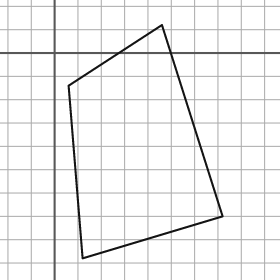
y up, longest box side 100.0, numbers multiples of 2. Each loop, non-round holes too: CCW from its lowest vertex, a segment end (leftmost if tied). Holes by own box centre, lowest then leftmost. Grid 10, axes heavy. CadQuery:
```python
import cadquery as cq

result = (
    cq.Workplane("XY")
    .moveTo(12.0, -88.0)
    .lineTo(72.0, -70.0)
    .lineTo(46.0, 12.0)
    .lineTo(6.0, -14.0)
    .close()
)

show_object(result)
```